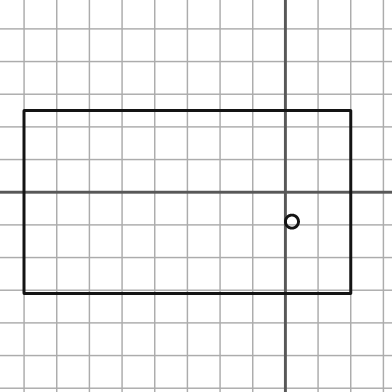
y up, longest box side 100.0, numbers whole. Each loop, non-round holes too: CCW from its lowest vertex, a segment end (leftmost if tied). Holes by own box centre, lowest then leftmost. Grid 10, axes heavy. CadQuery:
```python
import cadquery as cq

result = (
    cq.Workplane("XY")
    .moveTo(-80.0, -31.0)
    .lineTo(20.0, -31.0)
    .lineTo(20.0, 25.0)
    .lineTo(-80.0, 25.0)
    .close()
    .moveTo(2.0, -9.0)
    .circle(2.0)
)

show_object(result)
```